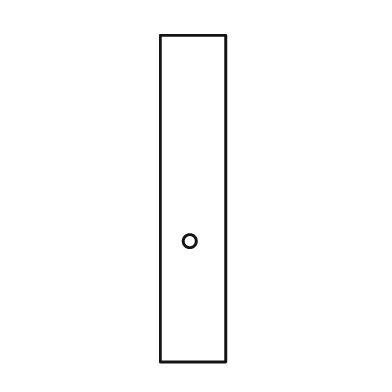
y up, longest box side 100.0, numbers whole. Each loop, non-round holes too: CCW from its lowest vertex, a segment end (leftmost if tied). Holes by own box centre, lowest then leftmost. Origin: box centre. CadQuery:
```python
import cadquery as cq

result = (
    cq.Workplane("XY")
    .moveTo(-10.0, -50.0)
    .lineTo(10.0, -50.0)
    .lineTo(10.0, 50.0)
    .lineTo(-10.0, 50.0)
    .close()
    .moveTo(-1.0, -13.0)
    .circle(2.0)
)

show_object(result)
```